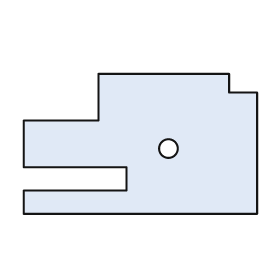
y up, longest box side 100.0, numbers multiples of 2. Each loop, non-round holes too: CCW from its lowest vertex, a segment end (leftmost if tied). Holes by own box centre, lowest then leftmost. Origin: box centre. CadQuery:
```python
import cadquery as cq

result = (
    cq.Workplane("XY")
    .moveTo(-50.0, -30.0)
    .lineTo(50.0, -30.0)
    .lineTo(50.0, 22.0)
    .lineTo(38.0, 22.0)
    .lineTo(38.0, 30.0)
    .lineTo(-18.0, 30.0)
    .lineTo(-18.0, 10.0)
    .lineTo(-50.0, 10.0)
    .lineTo(-50.0, -10.0)
    .lineTo(-6.0, -10.0)
    .lineTo(-6.0, -20.0)
    .lineTo(-50.0, -20.0)
    .close()
    .moveTo(12.0, -2.0)
    .circle(4.0)
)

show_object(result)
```